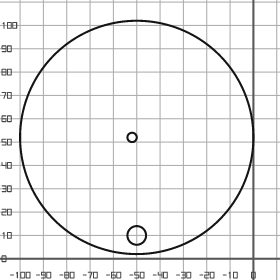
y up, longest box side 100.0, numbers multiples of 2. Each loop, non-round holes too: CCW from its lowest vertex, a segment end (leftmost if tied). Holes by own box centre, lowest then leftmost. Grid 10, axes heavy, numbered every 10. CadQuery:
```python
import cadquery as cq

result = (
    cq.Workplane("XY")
    .moveTo(-50.0, 52.0)
    .circle(50.0)
    .moveTo(-50.0, 10.0)
    .circle(4.0)
    .moveTo(-52.0, 52.0)
    .circle(2.0)
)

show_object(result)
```